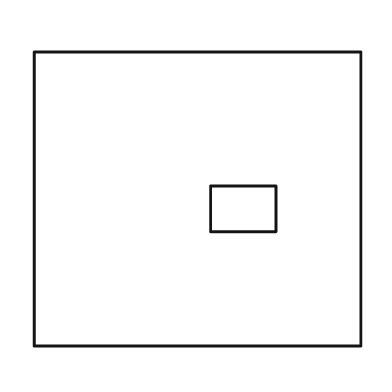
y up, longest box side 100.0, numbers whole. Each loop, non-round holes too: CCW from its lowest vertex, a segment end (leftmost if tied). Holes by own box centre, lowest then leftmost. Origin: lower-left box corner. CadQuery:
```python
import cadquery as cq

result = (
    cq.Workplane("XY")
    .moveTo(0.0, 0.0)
    .lineTo(100.0, 0.0)
    .lineTo(100.0, 90.0)
    .lineTo(0.0, 90.0)
    .close()
    .moveTo(54.0, 35.0)
    .lineTo(74.0, 35.0)
    .lineTo(74.0, 49.0)
    .lineTo(54.0, 49.0)
    .close()
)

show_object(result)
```